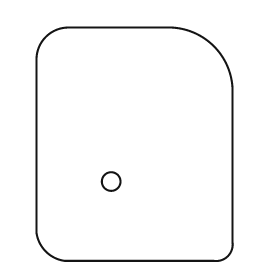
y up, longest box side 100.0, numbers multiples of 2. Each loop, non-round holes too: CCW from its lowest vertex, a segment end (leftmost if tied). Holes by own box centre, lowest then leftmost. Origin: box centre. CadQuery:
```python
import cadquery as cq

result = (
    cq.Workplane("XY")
    .moveTo(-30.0, -50.0)
    .lineTo(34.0, -50.0)
    .threePointArc((40.0, -48.0), (42.0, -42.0))
    .lineTo(42.0, 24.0)
    .threePointArc((34.0, 42.0), (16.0, 50.0))
    .lineTo(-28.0, 50.0)
    .threePointArc((-38.0, 46.0), (-42.0, 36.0))
    .lineTo(-42.0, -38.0)
    .threePointArc((-38.0, -46.0), (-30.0, -50.0))
    .close()
    .moveTo(-10.0, -16.0)
    .circle(4.0)
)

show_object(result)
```